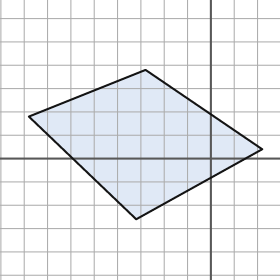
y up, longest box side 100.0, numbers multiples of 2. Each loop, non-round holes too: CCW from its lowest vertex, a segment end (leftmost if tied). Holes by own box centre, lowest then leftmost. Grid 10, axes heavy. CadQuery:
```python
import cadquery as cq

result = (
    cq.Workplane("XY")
    .moveTo(-32.0, -26.0)
    .lineTo(22.0, 4.0)
    .lineTo(-28.0, 38.0)
    .lineTo(-78.0, 18.0)
    .close()
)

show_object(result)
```